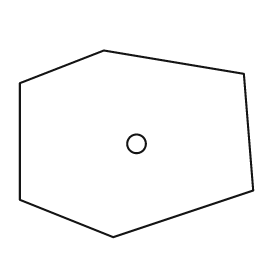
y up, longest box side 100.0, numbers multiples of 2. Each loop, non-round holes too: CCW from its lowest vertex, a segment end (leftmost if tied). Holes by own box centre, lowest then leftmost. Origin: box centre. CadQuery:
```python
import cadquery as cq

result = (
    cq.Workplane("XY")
    .moveTo(-10.0, -40.0)
    .lineTo(50.0, -20.0)
    .lineTo(46.0, 30.0)
    .lineTo(-14.0, 40.0)
    .lineTo(-50.0, 26.0)
    .lineTo(-50.0, -24.0)
    .close()
    .moveTo(0.0, 0.0)
    .circle(4.0)
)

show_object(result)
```